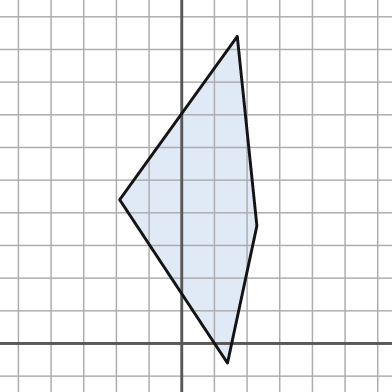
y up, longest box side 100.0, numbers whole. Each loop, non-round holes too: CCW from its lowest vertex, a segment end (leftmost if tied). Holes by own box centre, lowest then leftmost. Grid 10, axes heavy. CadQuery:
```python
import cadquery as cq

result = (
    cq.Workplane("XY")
    .moveTo(14.0, -6.0)
    .lineTo(23.0, 36.0)
    .lineTo(17.0, 94.0)
    .lineTo(-19.0, 44.0)
    .close()
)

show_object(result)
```